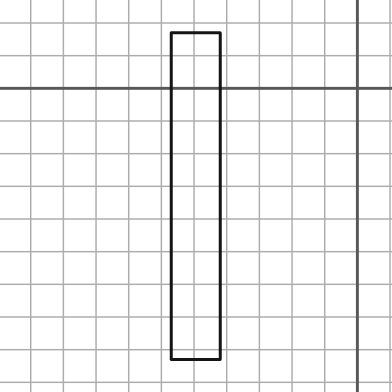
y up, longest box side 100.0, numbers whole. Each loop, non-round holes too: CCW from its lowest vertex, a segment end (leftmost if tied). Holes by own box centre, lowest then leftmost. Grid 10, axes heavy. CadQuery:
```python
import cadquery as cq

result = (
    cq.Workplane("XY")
    .moveTo(-57.0, -83.0)
    .lineTo(-42.0, -83.0)
    .lineTo(-42.0, 17.0)
    .lineTo(-57.0, 17.0)
    .close()
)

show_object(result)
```